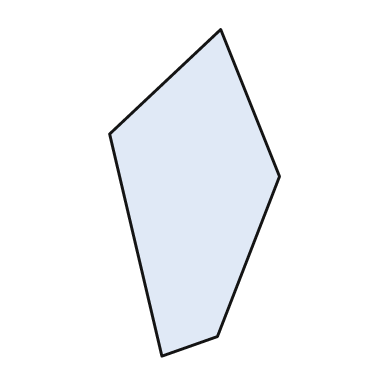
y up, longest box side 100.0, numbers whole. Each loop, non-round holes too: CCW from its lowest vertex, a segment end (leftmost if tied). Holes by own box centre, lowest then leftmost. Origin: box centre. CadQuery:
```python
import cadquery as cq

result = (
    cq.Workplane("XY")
    .moveTo(-10.0, -50.0)
    .lineTo(7.0, -44.0)
    .lineTo(26.0, 5.0)
    .lineTo(8.0, 50.0)
    .lineTo(-26.0, 18.0)
    .close()
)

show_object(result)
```